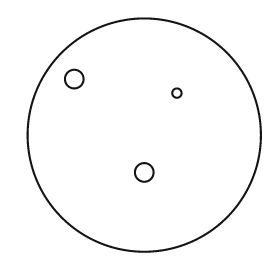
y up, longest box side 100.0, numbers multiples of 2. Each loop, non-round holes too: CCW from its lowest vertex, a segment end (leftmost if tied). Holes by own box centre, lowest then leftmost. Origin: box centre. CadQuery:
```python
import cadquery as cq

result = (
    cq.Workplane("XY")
    .moveTo(0.0, 0.0)
    .circle(50.0)
    .moveTo(0.0, -16.0)
    .circle(4.0)
    .moveTo(14.0, 18.0)
    .circle(2.0)
    .moveTo(-30.0, 24.0)
    .circle(4.0)
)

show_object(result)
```